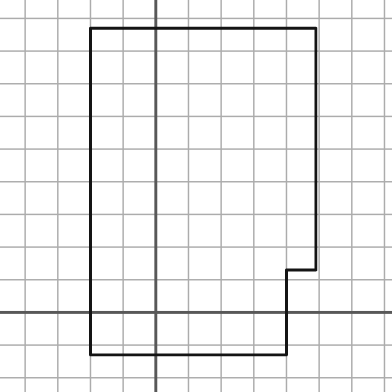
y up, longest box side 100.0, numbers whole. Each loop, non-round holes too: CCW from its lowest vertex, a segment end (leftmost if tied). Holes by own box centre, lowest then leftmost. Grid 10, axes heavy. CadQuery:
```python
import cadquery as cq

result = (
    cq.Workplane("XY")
    .moveTo(-20.0, -13.0)
    .lineTo(40.0, -13.0)
    .lineTo(40.0, 13.0)
    .lineTo(49.0, 13.0)
    .lineTo(49.0, 87.0)
    .lineTo(-20.0, 87.0)
    .close()
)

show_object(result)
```